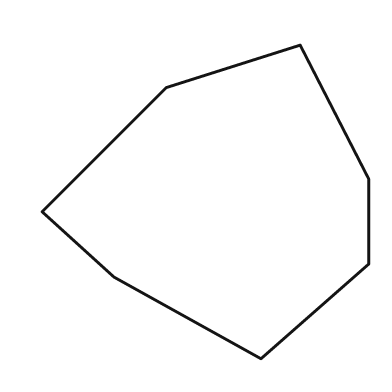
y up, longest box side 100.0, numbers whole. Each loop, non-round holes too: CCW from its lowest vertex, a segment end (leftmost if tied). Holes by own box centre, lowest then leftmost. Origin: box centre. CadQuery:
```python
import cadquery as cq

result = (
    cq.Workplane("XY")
    .moveTo(17.0, -48.0)
    .lineTo(50.0, -19.0)
    .lineTo(50.0, 7.0)
    .lineTo(29.0, 48.0)
    .lineTo(-12.0, 35.0)
    .lineTo(-50.0, -3.0)
    .lineTo(-28.0, -23.0)
    .close()
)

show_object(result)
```